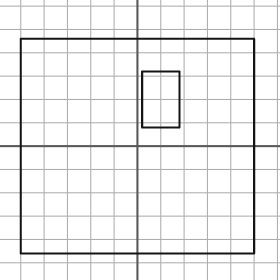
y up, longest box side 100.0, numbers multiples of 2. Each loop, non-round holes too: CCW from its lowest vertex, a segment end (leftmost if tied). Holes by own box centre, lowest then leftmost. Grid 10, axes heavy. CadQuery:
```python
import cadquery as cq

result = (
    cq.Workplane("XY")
    .moveTo(-50.0, -46.0)
    .lineTo(50.0, -46.0)
    .lineTo(50.0, 46.0)
    .lineTo(-50.0, 46.0)
    .close()
    .moveTo(2.0, 8.0)
    .lineTo(18.0, 8.0)
    .lineTo(18.0, 32.0)
    .lineTo(2.0, 32.0)
    .close()
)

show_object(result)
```